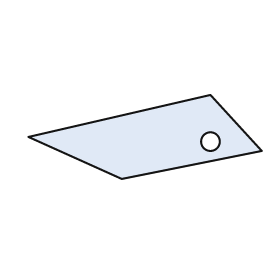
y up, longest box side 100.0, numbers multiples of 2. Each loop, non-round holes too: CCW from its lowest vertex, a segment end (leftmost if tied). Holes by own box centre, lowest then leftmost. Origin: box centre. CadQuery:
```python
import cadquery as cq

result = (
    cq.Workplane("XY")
    .moveTo(-10.0, -18.0)
    .lineTo(50.0, -6.0)
    .lineTo(28.0, 18.0)
    .lineTo(-50.0, 0.0)
    .close()
    .moveTo(28.0, -2.0)
    .circle(4.0)
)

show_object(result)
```